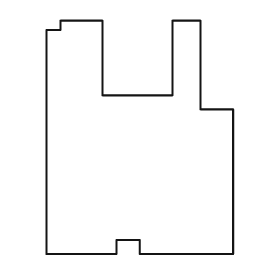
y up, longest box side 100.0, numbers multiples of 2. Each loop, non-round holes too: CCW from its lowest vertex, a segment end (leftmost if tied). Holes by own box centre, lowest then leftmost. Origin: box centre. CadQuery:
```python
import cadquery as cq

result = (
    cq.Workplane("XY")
    .moveTo(-40.0, -50.0)
    .lineTo(-10.0, -50.0)
    .lineTo(-10.0, -44.0)
    .lineTo(0.0, -44.0)
    .lineTo(0.0, -50.0)
    .lineTo(40.0, -50.0)
    .lineTo(40.0, 12.0)
    .lineTo(26.0, 12.0)
    .lineTo(26.0, 50.0)
    .lineTo(14.0, 50.0)
    .lineTo(14.0, 18.0)
    .lineTo(-16.0, 18.0)
    .lineTo(-16.0, 50.0)
    .lineTo(-34.0, 50.0)
    .lineTo(-34.0, 46.0)
    .lineTo(-40.0, 46.0)
    .close()
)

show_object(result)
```